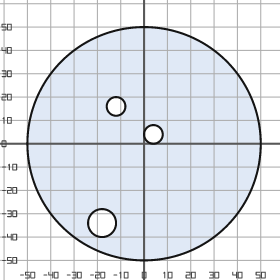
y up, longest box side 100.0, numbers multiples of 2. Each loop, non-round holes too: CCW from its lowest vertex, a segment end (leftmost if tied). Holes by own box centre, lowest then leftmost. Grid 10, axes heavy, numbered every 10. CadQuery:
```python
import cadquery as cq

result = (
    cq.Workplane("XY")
    .moveTo(0.0, 0.0)
    .circle(50.0)
    .moveTo(-18.0, -34.0)
    .circle(6.0)
    .moveTo(4.0, 4.0)
    .circle(4.0)
    .moveTo(-12.0, 16.0)
    .circle(4.0)
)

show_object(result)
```